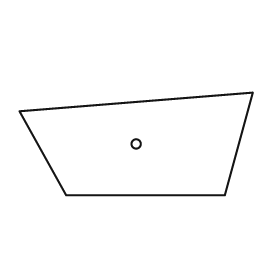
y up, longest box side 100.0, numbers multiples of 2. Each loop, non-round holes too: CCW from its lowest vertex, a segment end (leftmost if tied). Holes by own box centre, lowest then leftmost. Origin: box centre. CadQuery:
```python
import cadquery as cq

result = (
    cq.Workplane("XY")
    .moveTo(-30.0, -22.0)
    .lineTo(38.0, -22.0)
    .lineTo(50.0, 22.0)
    .lineTo(-50.0, 14.0)
    .close()
    .moveTo(0.0, 0.0)
    .circle(2.0)
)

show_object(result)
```